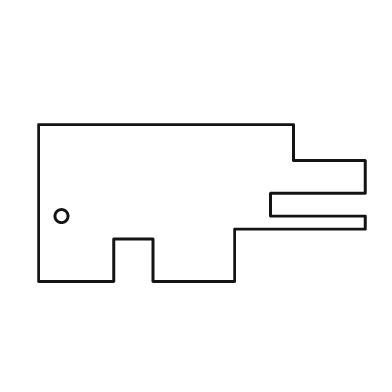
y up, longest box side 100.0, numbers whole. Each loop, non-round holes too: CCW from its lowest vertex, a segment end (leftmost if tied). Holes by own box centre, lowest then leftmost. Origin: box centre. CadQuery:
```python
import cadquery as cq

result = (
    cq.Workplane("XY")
    .moveTo(-50.0, -24.0)
    .lineTo(-27.0, -24.0)
    .lineTo(-27.0, -11.0)
    .lineTo(-15.0, -11.0)
    .lineTo(-15.0, -24.0)
    .lineTo(10.0, -24.0)
    .lineTo(10.0, -8.0)
    .lineTo(50.0, -8.0)
    .lineTo(50.0, -4.0)
    .lineTo(21.0, -4.0)
    .lineTo(21.0, 3.0)
    .lineTo(50.0, 3.0)
    .lineTo(50.0, 13.0)
    .lineTo(28.0, 13.0)
    .lineTo(28.0, 24.0)
    .lineTo(-50.0, 24.0)
    .close()
    .moveTo(-43.0, -4.0)
    .circle(2.0)
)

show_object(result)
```